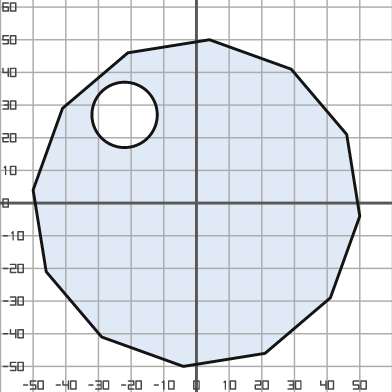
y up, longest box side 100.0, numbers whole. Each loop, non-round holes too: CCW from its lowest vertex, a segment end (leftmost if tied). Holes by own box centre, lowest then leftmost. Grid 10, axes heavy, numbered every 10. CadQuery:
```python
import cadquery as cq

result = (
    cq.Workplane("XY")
    .moveTo(-4.0, -50.0)
    .lineTo(21.0, -46.0)
    .lineTo(41.0, -29.0)
    .lineTo(50.0, -4.0)
    .lineTo(46.0, 21.0)
    .lineTo(29.0, 41.0)
    .lineTo(4.0, 50.0)
    .lineTo(-21.0, 46.0)
    .lineTo(-41.0, 29.0)
    .lineTo(-50.0, 4.0)
    .lineTo(-46.0, -21.0)
    .lineTo(-29.0, -41.0)
    .close()
    .moveTo(-22.0, 27.0)
    .circle(10.0)
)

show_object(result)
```